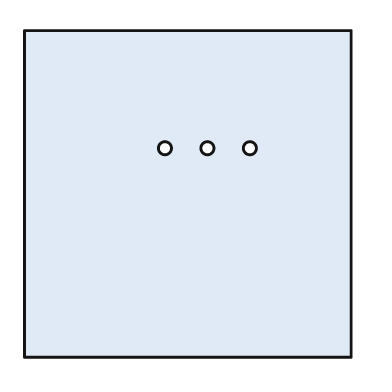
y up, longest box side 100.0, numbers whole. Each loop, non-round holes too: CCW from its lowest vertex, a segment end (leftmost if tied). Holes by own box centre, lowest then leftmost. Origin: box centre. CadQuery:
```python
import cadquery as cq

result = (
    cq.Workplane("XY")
    .moveTo(-50.0, -50.0)
    .lineTo(50.0, -50.0)
    .lineTo(50.0, 50.0)
    .lineTo(-50.0, 50.0)
    .close()
    .moveTo(-7.0, 14.0)
    .circle(2.0)
    .moveTo(6.0, 14.0)
    .circle(2.0)
    .moveTo(19.0, 14.0)
    .circle(2.0)
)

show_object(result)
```